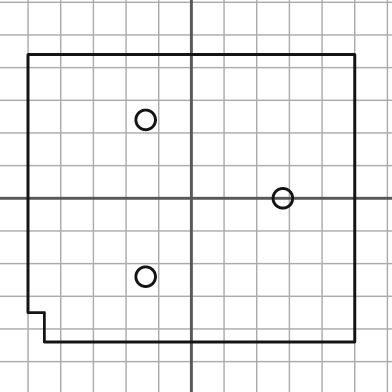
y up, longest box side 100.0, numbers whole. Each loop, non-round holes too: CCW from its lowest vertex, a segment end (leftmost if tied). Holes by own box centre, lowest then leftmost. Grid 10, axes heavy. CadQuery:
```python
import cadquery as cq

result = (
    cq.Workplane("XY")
    .moveTo(-45.0, -44.0)
    .lineTo(50.0, -44.0)
    .lineTo(50.0, 44.0)
    .lineTo(-50.0, 44.0)
    .lineTo(-50.0, -35.0)
    .lineTo(-45.0, -35.0)
    .close()
    .moveTo(-14.0, -24.0)
    .circle(3.0)
    .moveTo(28.0, 0.0)
    .circle(3.0)
    .moveTo(-14.0, 24.0)
    .circle(3.0)
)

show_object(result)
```